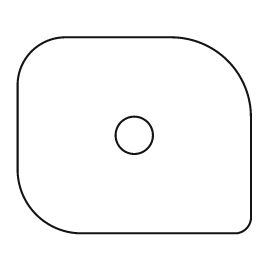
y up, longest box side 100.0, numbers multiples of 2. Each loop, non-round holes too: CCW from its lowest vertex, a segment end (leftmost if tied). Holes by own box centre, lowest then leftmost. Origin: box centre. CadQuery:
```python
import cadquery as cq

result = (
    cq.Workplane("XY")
    .moveTo(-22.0, -42.0)
    .lineTo(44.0, -42.0)
    .threePointArc((48.0, -40.0), (50.0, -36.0))
    .lineTo(50.0, 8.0)
    .threePointArc((40.0, 32.0), (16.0, 42.0))
    .lineTo(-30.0, 42.0)
    .threePointArc((-44.0, 36.0), (-50.0, 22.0))
    .lineTo(-50.0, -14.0)
    .threePointArc((-42.0, -34.0), (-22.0, -42.0))
    .close()
    .moveTo(0.0, 0.0)
    .circle(8.0)
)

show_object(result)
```